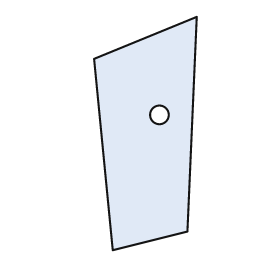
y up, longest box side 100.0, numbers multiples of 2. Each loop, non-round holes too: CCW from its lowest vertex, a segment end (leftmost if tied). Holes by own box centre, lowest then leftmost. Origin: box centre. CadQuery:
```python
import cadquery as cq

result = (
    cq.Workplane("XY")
    .moveTo(-14.0, -50.0)
    .lineTo(18.0, -42.0)
    .lineTo(22.0, 50.0)
    .lineTo(-22.0, 32.0)
    .close()
    .moveTo(6.0, 8.0)
    .circle(4.0)
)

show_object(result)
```